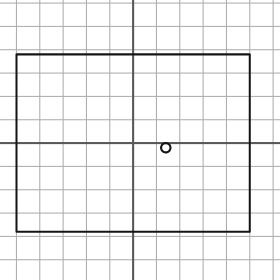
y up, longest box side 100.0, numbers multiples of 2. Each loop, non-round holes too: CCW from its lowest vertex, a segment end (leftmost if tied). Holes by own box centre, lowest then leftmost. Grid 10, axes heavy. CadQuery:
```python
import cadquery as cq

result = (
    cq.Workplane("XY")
    .moveTo(-50.0, -38.0)
    .lineTo(50.0, -38.0)
    .lineTo(50.0, 38.0)
    .lineTo(-50.0, 38.0)
    .close()
    .moveTo(14.0, -2.0)
    .circle(2.0)
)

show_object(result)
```